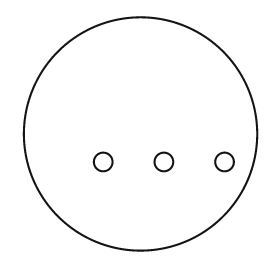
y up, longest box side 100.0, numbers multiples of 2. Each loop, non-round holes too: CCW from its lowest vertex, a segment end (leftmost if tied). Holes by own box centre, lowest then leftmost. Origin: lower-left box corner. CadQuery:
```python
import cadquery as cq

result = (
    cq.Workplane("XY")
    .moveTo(50.0, 50.0)
    .circle(50.0)
    .moveTo(34.0, 38.0)
    .circle(4.0)
    .moveTo(60.0, 38.0)
    .circle(4.0)
    .moveTo(86.0, 38.0)
    .circle(4.0)
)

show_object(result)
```